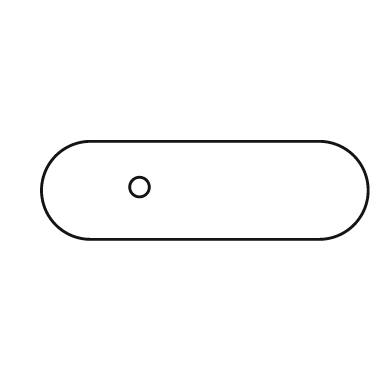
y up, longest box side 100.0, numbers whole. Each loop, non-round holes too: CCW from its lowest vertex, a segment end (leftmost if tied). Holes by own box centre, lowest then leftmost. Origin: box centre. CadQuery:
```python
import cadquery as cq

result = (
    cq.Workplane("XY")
    .moveTo(-35.0, -15.0)
    .lineTo(35.0, -15.0)
    .threePointArc((50.0, 0.0), (35.0, 15.0))
    .lineTo(-35.0, 15.0)
    .threePointArc((-50.0, 0.0), (-35.0, -15.0))
    .close()
    .moveTo(-20.0, 1.0)
    .circle(3.0)
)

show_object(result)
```